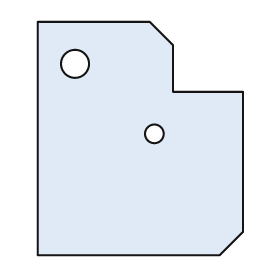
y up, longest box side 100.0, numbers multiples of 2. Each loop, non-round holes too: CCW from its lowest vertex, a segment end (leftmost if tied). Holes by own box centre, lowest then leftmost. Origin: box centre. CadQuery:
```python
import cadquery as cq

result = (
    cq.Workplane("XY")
    .moveTo(-44.0, -50.0)
    .lineTo(34.0, -50.0)
    .lineTo(44.0, -40.0)
    .lineTo(44.0, 20.0)
    .lineTo(14.0, 20.0)
    .lineTo(14.0, 40.0)
    .lineTo(4.0, 50.0)
    .lineTo(-44.0, 50.0)
    .close()
    .moveTo(6.0, 2.0)
    .circle(4.0)
    .moveTo(-28.0, 32.0)
    .circle(6.0)
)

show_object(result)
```